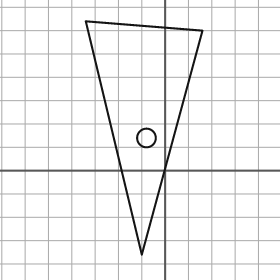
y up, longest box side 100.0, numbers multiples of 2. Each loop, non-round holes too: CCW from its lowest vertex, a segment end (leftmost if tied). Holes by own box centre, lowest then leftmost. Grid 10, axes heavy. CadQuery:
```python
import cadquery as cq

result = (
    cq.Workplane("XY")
    .moveTo(-10.0, -36.0)
    .lineTo(16.0, 60.0)
    .lineTo(-34.0, 64.0)
    .close()
    .moveTo(-8.0, 14.0)
    .circle(4.0)
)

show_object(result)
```